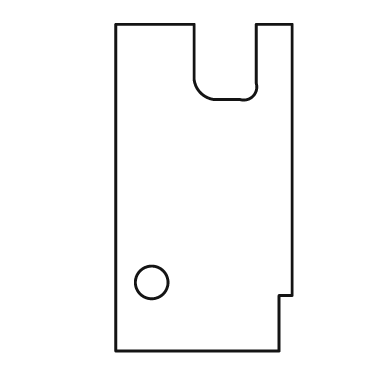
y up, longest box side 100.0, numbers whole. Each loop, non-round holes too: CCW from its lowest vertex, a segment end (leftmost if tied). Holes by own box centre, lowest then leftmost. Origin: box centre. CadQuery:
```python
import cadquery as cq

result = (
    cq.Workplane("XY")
    .moveTo(-27.0, -50.0)
    .lineTo(23.0, -50.0)
    .lineTo(23.0, -33.0)
    .lineTo(27.0, -33.0)
    .lineTo(27.0, 50.0)
    .lineTo(16.0, 50.0)
    .lineTo(16.0, 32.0)
    .threePointArc((15.0, 28.0), (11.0, 27.0))
    .lineTo(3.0, 27.0)
    .threePointArc((-1.0, 29.0), (-3.0, 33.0))
    .lineTo(-3.0, 50.0)
    .lineTo(-27.0, 50.0)
    .close()
    .moveTo(-16.0, -29.0)
    .circle(5.0)
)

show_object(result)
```